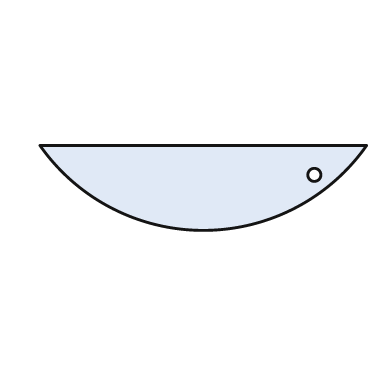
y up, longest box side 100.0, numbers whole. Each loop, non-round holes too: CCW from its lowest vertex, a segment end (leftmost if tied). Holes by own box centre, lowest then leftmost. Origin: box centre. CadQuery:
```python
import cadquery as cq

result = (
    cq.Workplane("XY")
    .moveTo(-50.0, 13.0)
    .threePointArc((0.0, -13.0), (50.0, 13.0))
    .close()
    .moveTo(34.0, 4.0)
    .circle(2.0)
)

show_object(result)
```